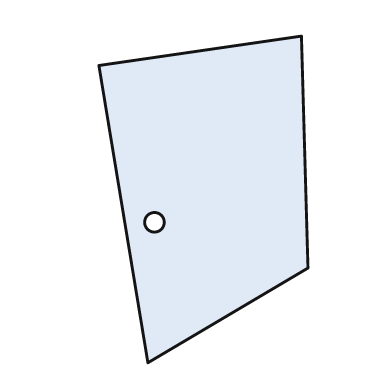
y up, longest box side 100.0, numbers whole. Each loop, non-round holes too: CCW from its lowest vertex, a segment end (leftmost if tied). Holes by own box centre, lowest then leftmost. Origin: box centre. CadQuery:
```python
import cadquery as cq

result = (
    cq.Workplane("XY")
    .moveTo(-17.0, -50.0)
    .lineTo(32.0, -21.0)
    .lineTo(30.0, 50.0)
    .lineTo(-32.0, 41.0)
    .close()
    .moveTo(-15.0, -7.0)
    .circle(3.0)
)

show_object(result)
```